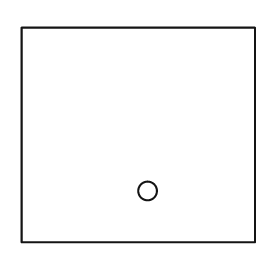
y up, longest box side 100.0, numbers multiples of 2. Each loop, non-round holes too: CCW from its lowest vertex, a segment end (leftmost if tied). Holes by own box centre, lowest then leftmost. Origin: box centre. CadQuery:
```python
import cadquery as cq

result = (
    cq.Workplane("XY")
    .moveTo(-50.0, -46.0)
    .lineTo(50.0, -46.0)
    .lineTo(50.0, 46.0)
    .lineTo(-50.0, 46.0)
    .close()
    .moveTo(4.0, -24.0)
    .circle(4.0)
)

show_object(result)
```